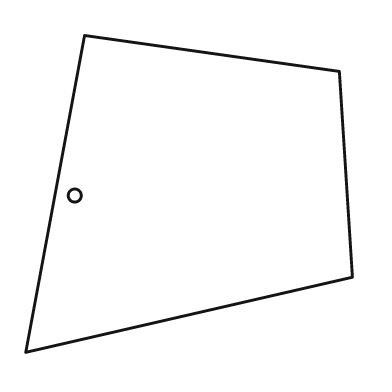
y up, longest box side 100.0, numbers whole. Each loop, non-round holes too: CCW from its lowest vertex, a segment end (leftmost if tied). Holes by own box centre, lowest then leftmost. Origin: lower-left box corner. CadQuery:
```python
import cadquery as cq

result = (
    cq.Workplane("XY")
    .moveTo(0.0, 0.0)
    .lineTo(100.0, 23.0)
    .lineTo(96.0, 86.0)
    .lineTo(18.0, 97.0)
    .close()
    .moveTo(15.0, 48.0)
    .circle(2.0)
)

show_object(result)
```